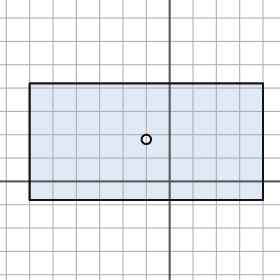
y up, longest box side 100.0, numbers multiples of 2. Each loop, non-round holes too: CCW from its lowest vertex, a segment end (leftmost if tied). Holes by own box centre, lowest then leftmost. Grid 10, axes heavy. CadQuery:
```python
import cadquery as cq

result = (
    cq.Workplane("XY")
    .moveTo(-60.0, -8.0)
    .lineTo(40.0, -8.0)
    .lineTo(40.0, 42.0)
    .lineTo(-60.0, 42.0)
    .close()
    .moveTo(-10.0, 18.0)
    .circle(2.0)
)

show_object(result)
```